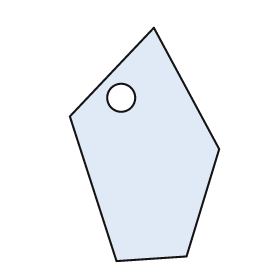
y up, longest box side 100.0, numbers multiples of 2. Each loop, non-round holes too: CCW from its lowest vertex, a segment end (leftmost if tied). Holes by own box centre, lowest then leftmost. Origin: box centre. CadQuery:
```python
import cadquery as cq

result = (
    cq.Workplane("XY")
    .moveTo(-12.0, -50.0)
    .lineTo(18.0, -48.0)
    .lineTo(32.0, -2.0)
    .lineTo(4.0, 50.0)
    .lineTo(-32.0, 12.0)
    .close()
    .moveTo(-10.0, 20.0)
    .circle(6.0)
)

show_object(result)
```